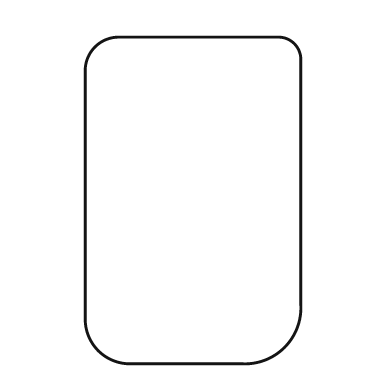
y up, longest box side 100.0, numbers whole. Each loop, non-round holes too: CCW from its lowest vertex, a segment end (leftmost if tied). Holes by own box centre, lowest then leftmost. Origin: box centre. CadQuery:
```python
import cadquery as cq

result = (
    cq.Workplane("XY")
    .moveTo(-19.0, -50.0)
    .lineTo(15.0, -50.0)
    .threePointArc((28.0, -45.0), (33.0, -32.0))
    .lineTo(33.0, 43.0)
    .threePointArc((31.0, 48.0), (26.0, 50.0))
    .lineTo(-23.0, 50.0)
    .threePointArc((-30.0, 47.0), (-33.0, 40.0))
    .lineTo(-33.0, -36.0)
    .threePointArc((-29.0, -46.0), (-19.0, -50.0))
    .close()
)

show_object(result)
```